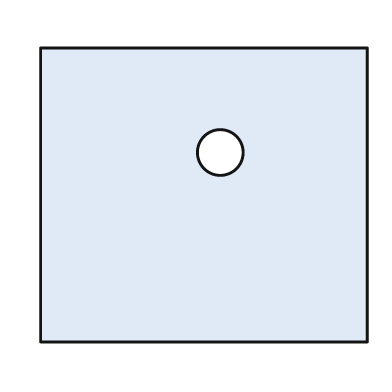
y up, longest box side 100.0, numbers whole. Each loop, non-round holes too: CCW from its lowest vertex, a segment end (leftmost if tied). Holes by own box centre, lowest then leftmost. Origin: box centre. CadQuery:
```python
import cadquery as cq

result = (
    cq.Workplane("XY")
    .moveTo(-50.0, -45.0)
    .lineTo(50.0, -45.0)
    .lineTo(50.0, 45.0)
    .lineTo(-50.0, 45.0)
    .close()
    .moveTo(5.0, 13.0)
    .circle(7.0)
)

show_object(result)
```